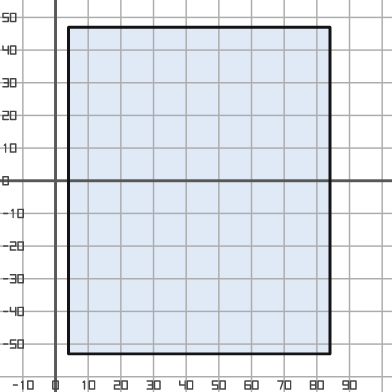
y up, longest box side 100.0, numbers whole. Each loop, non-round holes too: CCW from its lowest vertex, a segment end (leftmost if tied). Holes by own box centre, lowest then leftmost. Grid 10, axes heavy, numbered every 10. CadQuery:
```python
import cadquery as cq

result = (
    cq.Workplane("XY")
    .moveTo(4.0, -53.0)
    .lineTo(84.0, -53.0)
    .lineTo(84.0, 47.0)
    .lineTo(4.0, 47.0)
    .close()
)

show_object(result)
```